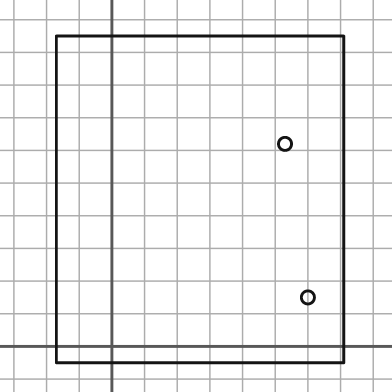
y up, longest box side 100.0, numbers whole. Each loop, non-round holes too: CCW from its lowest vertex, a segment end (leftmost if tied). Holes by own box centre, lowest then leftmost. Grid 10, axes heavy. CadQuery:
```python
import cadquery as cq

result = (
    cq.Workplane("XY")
    .moveTo(-17.0, -5.0)
    .lineTo(71.0, -5.0)
    .lineTo(71.0, 95.0)
    .lineTo(-17.0, 95.0)
    .close()
    .moveTo(60.0, 15.0)
    .circle(2.0)
    .moveTo(53.0, 62.0)
    .circle(2.0)
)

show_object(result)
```